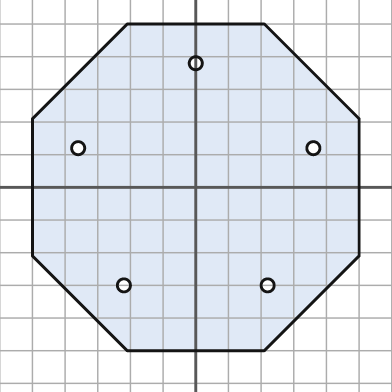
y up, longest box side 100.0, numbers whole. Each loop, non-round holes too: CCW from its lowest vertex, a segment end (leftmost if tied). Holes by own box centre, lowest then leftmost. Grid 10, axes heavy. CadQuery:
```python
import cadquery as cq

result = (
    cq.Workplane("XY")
    .moveTo(-21.0, -50.0)
    .lineTo(21.0, -50.0)
    .lineTo(50.0, -21.0)
    .lineTo(50.0, 21.0)
    .lineTo(21.0, 50.0)
    .lineTo(-21.0, 50.0)
    .lineTo(-50.0, 21.0)
    .lineTo(-50.0, -21.0)
    .close()
    .moveTo(-22.0, -30.0)
    .circle(2.0)
    .moveTo(22.0, -30.0)
    .circle(2.0)
    .moveTo(-36.0, 12.0)
    .circle(2.0)
    .moveTo(36.0, 12.0)
    .circle(2.0)
    .moveTo(0.0, 38.0)
    .circle(2.0)
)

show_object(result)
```